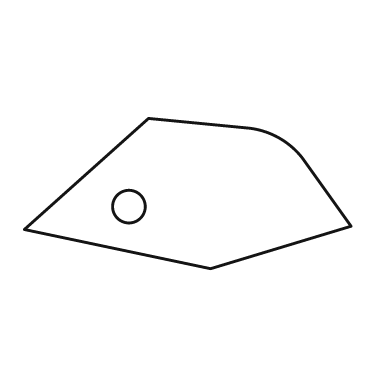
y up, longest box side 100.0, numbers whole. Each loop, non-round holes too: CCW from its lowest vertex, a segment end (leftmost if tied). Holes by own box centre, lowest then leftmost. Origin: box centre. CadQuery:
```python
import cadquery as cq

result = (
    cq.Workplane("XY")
    .moveTo(7.0, -23.0)
    .lineTo(50.0, -10.0)
    .lineTo(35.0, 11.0)
    .threePointArc((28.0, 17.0), (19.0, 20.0))
    .lineTo(-12.0, 23.0)
    .lineTo(-50.0, -11.0)
    .close()
    .moveTo(-18.0, -4.0)
    .circle(5.0)
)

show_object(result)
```